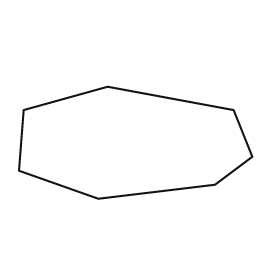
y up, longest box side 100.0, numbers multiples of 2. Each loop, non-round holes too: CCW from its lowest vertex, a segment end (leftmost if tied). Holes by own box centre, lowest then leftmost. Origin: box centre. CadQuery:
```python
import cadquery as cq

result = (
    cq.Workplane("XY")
    .moveTo(-16.0, -24.0)
    .lineTo(34.0, -18.0)
    .lineTo(50.0, -6.0)
    .lineTo(42.0, 14.0)
    .lineTo(-12.0, 24.0)
    .lineTo(-48.0, 14.0)
    .lineTo(-50.0, -12.0)
    .close()
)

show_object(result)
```